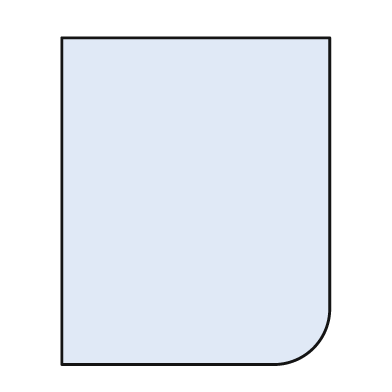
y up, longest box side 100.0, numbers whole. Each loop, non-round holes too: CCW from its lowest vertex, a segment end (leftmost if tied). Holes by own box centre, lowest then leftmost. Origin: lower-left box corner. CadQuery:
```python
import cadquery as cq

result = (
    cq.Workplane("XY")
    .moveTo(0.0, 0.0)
    .lineTo(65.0, 0.0)
    .threePointArc((77.0, 5.0), (82.0, 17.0))
    .lineTo(82.0, 100.0)
    .lineTo(0.0, 100.0)
    .close()
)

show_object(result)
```